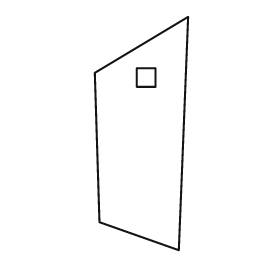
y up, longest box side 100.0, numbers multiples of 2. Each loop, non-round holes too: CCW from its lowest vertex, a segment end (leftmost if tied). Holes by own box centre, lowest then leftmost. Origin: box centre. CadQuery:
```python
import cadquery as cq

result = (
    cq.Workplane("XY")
    .moveTo(16.0, -50.0)
    .lineTo(20.0, 50.0)
    .lineTo(-20.0, 26.0)
    .lineTo(-18.0, -38.0)
    .close()
    .moveTo(-2.0, 20.0)
    .lineTo(6.0, 20.0)
    .lineTo(6.0, 28.0)
    .lineTo(-2.0, 28.0)
    .close()
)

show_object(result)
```